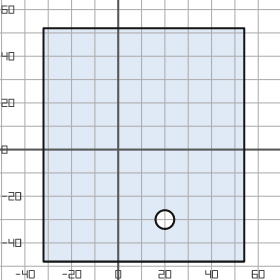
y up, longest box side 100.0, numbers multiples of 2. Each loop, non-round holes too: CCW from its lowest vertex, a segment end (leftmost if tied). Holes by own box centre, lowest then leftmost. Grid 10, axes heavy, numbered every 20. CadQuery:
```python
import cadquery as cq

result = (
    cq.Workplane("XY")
    .moveTo(-32.0, -48.0)
    .lineTo(54.0, -48.0)
    .lineTo(54.0, 52.0)
    .lineTo(-32.0, 52.0)
    .close()
    .moveTo(20.0, -30.0)
    .circle(4.0)
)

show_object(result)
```